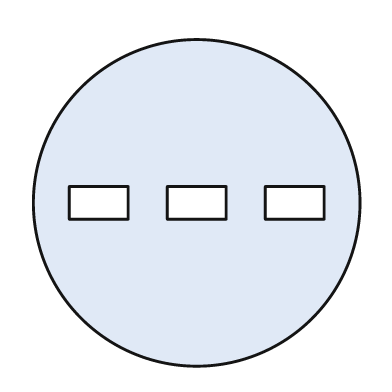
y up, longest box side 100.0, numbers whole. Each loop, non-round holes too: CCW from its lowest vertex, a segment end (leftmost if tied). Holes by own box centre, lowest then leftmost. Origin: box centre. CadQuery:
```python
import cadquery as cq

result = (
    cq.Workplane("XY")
    .moveTo(0.0, 0.0)
    .circle(50.0)
    .moveTo(-39.0, -5.0)
    .lineTo(-21.0, -5.0)
    .lineTo(-21.0, 5.0)
    .lineTo(-39.0, 5.0)
    .close()
    .moveTo(-9.0, -5.0)
    .lineTo(9.0, -5.0)
    .lineTo(9.0, 5.0)
    .lineTo(-9.0, 5.0)
    .close()
    .moveTo(21.0, -5.0)
    .lineTo(39.0, -5.0)
    .lineTo(39.0, 5.0)
    .lineTo(21.0, 5.0)
    .close()
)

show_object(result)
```